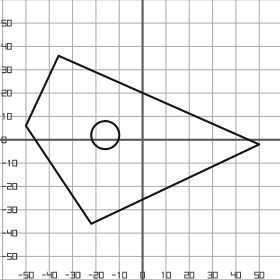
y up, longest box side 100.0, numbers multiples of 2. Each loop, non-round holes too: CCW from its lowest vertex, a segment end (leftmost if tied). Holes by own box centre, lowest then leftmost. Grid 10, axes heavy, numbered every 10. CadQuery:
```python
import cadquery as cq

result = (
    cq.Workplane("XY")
    .moveTo(-22.0, -36.0)
    .lineTo(50.0, -2.0)
    .lineTo(-36.0, 36.0)
    .lineTo(-50.0, 6.0)
    .close()
    .moveTo(-16.0, 2.0)
    .circle(6.0)
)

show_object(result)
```